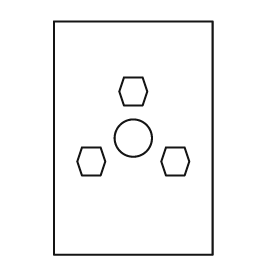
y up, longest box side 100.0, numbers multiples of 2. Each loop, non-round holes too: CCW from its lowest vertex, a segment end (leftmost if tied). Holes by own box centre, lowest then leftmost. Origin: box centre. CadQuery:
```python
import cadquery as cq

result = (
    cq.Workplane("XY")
    .moveTo(-34.0, -50.0)
    .lineTo(34.0, -50.0)
    .lineTo(34.0, 50.0)
    .lineTo(-34.0, 50.0)
    .close()
    .moveTo(-22.0, -16.0)
    .lineTo(-14.0, -16.0)
    .lineTo(-12.0, -10.0)
    .lineTo(-14.0, -4.0)
    .lineTo(-22.0, -4.0)
    .lineTo(-24.0, -10.0)
    .close()
    .moveTo(14.0, -16.0)
    .lineTo(22.0, -16.0)
    .lineTo(24.0, -10.0)
    .lineTo(22.0, -4.0)
    .lineTo(14.0, -4.0)
    .lineTo(12.0, -10.0)
    .close()
    .moveTo(0.0, 0.0)
    .circle(8.0)
    .moveTo(-4.0, 14.0)
    .lineTo(4.0, 14.0)
    .lineTo(6.0, 20.0)
    .lineTo(4.0, 26.0)
    .lineTo(-4.0, 26.0)
    .lineTo(-6.0, 20.0)
    .close()
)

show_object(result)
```